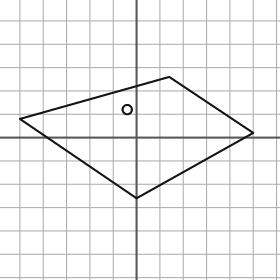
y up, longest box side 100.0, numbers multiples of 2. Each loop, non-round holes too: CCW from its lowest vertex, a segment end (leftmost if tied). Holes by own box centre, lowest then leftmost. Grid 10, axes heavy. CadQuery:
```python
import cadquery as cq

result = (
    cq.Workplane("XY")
    .moveTo(0.0, -26.0)
    .lineTo(50.0, 2.0)
    .lineTo(14.0, 26.0)
    .lineTo(-50.0, 8.0)
    .close()
    .moveTo(-4.0, 12.0)
    .circle(2.0)
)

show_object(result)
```